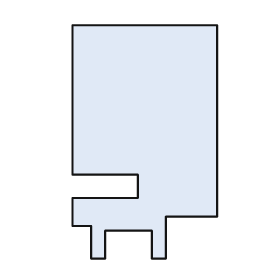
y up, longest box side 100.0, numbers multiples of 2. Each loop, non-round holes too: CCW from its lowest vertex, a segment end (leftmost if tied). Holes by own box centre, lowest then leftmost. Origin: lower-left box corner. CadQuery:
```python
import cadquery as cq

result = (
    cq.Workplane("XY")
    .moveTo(8.0, 0.0)
    .lineTo(14.0, 0.0)
    .lineTo(14.0, 12.0)
    .lineTo(34.0, 12.0)
    .lineTo(34.0, 0.0)
    .lineTo(40.0, 0.0)
    .lineTo(40.0, 18.0)
    .lineTo(62.0, 18.0)
    .lineTo(62.0, 100.0)
    .lineTo(0.0, 100.0)
    .lineTo(0.0, 36.0)
    .lineTo(28.0, 36.0)
    .lineTo(28.0, 26.0)
    .lineTo(0.0, 26.0)
    .lineTo(0.0, 14.0)
    .lineTo(8.0, 14.0)
    .close()
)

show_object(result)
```